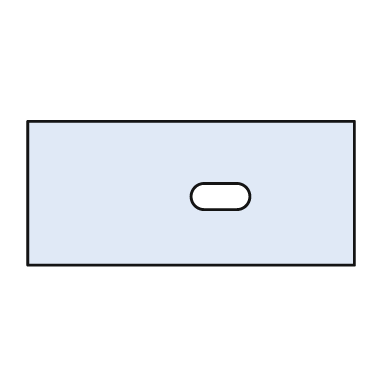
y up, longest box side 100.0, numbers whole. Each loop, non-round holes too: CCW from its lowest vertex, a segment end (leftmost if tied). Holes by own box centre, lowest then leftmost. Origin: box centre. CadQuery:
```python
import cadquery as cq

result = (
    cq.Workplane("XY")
    .moveTo(-50.0, -22.0)
    .lineTo(50.0, -22.0)
    .lineTo(50.0, 22.0)
    .lineTo(-50.0, 22.0)
    .close()
    .moveTo(4.0, -5.0)
    .lineTo(14.0, -5.0)
    .threePointArc((18.0, -1.0), (14.0, 3.0))
    .lineTo(4.0, 3.0)
    .threePointArc((0.0, -1.0), (4.0, -5.0))
    .close()
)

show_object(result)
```